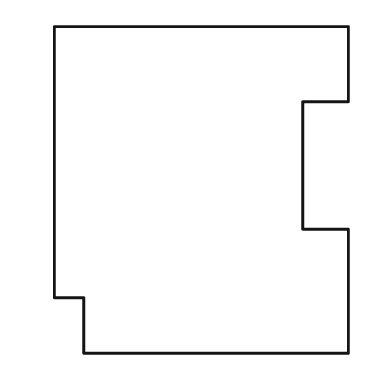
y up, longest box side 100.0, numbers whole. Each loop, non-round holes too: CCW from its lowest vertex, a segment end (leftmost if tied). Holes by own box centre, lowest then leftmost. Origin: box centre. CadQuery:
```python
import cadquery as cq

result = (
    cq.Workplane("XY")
    .moveTo(-36.0, -50.0)
    .lineTo(45.0, -50.0)
    .lineTo(45.0, -12.0)
    .lineTo(31.0, -12.0)
    .lineTo(31.0, 27.0)
    .lineTo(45.0, 27.0)
    .lineTo(45.0, 50.0)
    .lineTo(-45.0, 50.0)
    .lineTo(-45.0, -33.0)
    .lineTo(-36.0, -33.0)
    .close()
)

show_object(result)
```